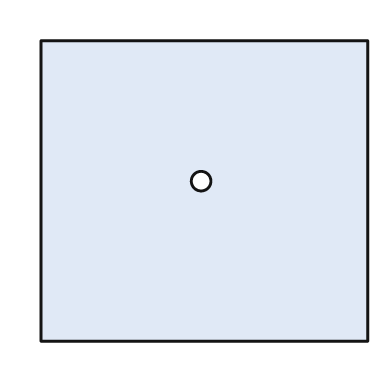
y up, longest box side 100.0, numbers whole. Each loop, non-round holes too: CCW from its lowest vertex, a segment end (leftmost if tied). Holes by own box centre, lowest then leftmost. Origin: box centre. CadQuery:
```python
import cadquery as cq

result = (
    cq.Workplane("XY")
    .moveTo(-50.0, -46.0)
    .lineTo(50.0, -46.0)
    .lineTo(50.0, 46.0)
    .lineTo(-50.0, 46.0)
    .close()
    .moveTo(-1.0, 3.0)
    .circle(3.0)
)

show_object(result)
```